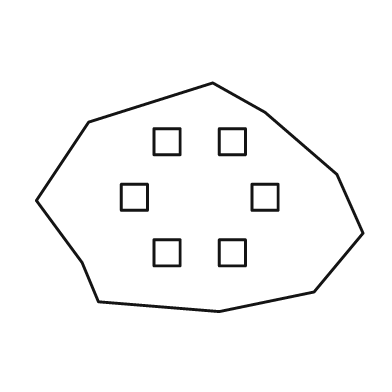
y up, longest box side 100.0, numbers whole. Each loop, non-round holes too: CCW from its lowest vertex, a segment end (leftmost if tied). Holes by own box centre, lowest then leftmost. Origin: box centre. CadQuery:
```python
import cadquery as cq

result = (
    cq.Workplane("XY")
    .moveTo(6.0, -35.0)
    .lineTo(35.0, -29.0)
    .lineTo(50.0, -11.0)
    .lineTo(42.0, 7.0)
    .lineTo(20.0, 26.0)
    .lineTo(4.0, 35.0)
    .lineTo(-34.0, 23.0)
    .lineTo(-50.0, -1.0)
    .lineTo(-36.0, -20.0)
    .lineTo(-31.0, -32.0)
    .close()
    .moveTo(-14.0, -21.0)
    .lineTo(-6.0, -21.0)
    .lineTo(-6.0, -13.0)
    .lineTo(-14.0, -13.0)
    .close()
    .moveTo(6.0, -21.0)
    .lineTo(14.0, -21.0)
    .lineTo(14.0, -13.0)
    .lineTo(6.0, -13.0)
    .close()
    .moveTo(-24.0, -4.0)
    .lineTo(-16.0, -4.0)
    .lineTo(-16.0, 4.0)
    .lineTo(-24.0, 4.0)
    .close()
    .moveTo(16.0, -4.0)
    .lineTo(24.0, -4.0)
    .lineTo(24.0, 4.0)
    .lineTo(16.0, 4.0)
    .close()
    .moveTo(-14.0, 13.0)
    .lineTo(-6.0, 13.0)
    .lineTo(-6.0, 21.0)
    .lineTo(-14.0, 21.0)
    .close()
    .moveTo(6.0, 13.0)
    .lineTo(14.0, 13.0)
    .lineTo(14.0, 21.0)
    .lineTo(6.0, 21.0)
    .close()
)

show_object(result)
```